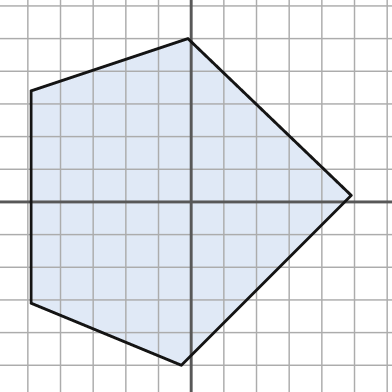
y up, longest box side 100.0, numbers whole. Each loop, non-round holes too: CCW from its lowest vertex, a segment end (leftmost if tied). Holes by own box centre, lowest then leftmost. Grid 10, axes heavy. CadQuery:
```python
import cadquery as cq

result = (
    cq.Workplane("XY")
    .moveTo(-3.0, -50.0)
    .lineTo(49.0, 2.0)
    .lineTo(-1.0, 50.0)
    .lineTo(-49.0, 34.0)
    .lineTo(-49.0, -31.0)
    .close()
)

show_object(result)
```